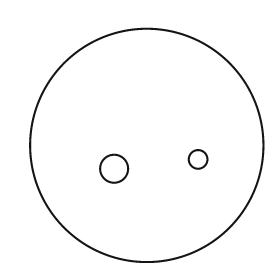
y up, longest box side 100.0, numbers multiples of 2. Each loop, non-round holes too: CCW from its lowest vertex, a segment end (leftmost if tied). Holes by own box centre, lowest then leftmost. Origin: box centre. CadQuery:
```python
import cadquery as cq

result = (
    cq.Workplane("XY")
    .moveTo(0.0, 0.0)
    .circle(50.0)
    .moveTo(-14.0, -10.0)
    .circle(6.0)
    .moveTo(22.0, -6.0)
    .circle(4.0)
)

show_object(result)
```